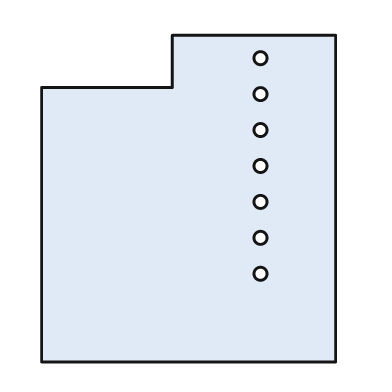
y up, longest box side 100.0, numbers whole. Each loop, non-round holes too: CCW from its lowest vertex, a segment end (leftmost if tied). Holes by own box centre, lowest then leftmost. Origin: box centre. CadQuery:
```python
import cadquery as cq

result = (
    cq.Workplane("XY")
    .moveTo(-45.0, -50.0)
    .lineTo(45.0, -50.0)
    .lineTo(45.0, 50.0)
    .lineTo(-5.0, 50.0)
    .lineTo(-5.0, 34.0)
    .lineTo(-45.0, 34.0)
    .close()
    .moveTo(22.0, -23.0)
    .circle(2.0)
    .moveTo(22.0, -12.0)
    .circle(2.0)
    .moveTo(22.0, -1.0)
    .circle(2.0)
    .moveTo(22.0, 10.0)
    .circle(2.0)
    .moveTo(22.0, 21.0)
    .circle(2.0)
    .moveTo(22.0, 32.0)
    .circle(2.0)
    .moveTo(22.0, 43.0)
    .circle(2.0)
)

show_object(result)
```